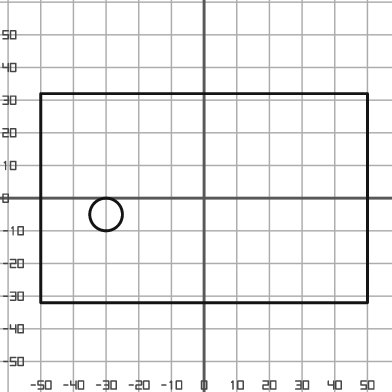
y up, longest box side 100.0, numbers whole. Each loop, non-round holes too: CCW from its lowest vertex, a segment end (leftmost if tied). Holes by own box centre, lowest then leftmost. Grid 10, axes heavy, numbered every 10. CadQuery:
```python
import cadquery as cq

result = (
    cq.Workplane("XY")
    .moveTo(-50.0, -32.0)
    .lineTo(50.0, -32.0)
    .lineTo(50.0, 32.0)
    .lineTo(-50.0, 32.0)
    .close()
    .moveTo(-30.0, -5.0)
    .circle(5.0)
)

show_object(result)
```